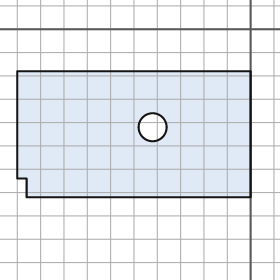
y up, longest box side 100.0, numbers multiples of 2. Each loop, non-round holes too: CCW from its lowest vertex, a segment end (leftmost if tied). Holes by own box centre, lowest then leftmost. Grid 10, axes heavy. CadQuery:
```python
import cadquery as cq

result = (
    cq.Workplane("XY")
    .moveTo(-96.0, -72.0)
    .lineTo(0.0, -72.0)
    .lineTo(0.0, -18.0)
    .lineTo(-100.0, -18.0)
    .lineTo(-100.0, -64.0)
    .lineTo(-96.0, -64.0)
    .close()
    .moveTo(-42.0, -42.0)
    .circle(6.0)
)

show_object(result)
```